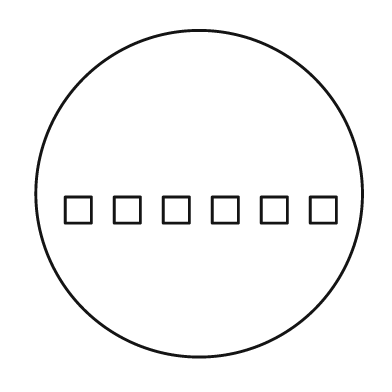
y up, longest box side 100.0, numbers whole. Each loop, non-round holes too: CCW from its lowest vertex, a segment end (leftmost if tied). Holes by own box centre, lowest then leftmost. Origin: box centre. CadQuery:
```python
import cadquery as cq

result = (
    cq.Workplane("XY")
    .moveTo(0.0, 0.0)
    .circle(50.0)
    .moveTo(-41.0, -9.0)
    .lineTo(-33.0, -9.0)
    .lineTo(-33.0, -1.0)
    .lineTo(-41.0, -1.0)
    .close()
    .moveTo(-26.0, -9.0)
    .lineTo(-18.0, -9.0)
    .lineTo(-18.0, -1.0)
    .lineTo(-26.0, -1.0)
    .close()
    .moveTo(-11.0, -9.0)
    .lineTo(-3.0, -9.0)
    .lineTo(-3.0, -1.0)
    .lineTo(-11.0, -1.0)
    .close()
    .moveTo(4.0, -9.0)
    .lineTo(12.0, -9.0)
    .lineTo(12.0, -1.0)
    .lineTo(4.0, -1.0)
    .close()
    .moveTo(19.0, -9.0)
    .lineTo(27.0, -9.0)
    .lineTo(27.0, -1.0)
    .lineTo(19.0, -1.0)
    .close()
    .moveTo(34.0, -9.0)
    .lineTo(42.0, -9.0)
    .lineTo(42.0, -1.0)
    .lineTo(34.0, -1.0)
    .close()
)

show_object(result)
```